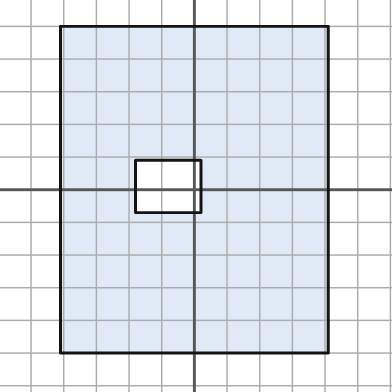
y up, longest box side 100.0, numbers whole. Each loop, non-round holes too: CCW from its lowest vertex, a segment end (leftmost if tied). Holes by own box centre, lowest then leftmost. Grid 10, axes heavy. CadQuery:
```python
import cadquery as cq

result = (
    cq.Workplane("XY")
    .moveTo(-41.0, -50.0)
    .lineTo(41.0, -50.0)
    .lineTo(41.0, 50.0)
    .lineTo(-41.0, 50.0)
    .close()
    .moveTo(-18.0, -7.0)
    .lineTo(2.0, -7.0)
    .lineTo(2.0, 9.0)
    .lineTo(-18.0, 9.0)
    .close()
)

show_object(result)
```